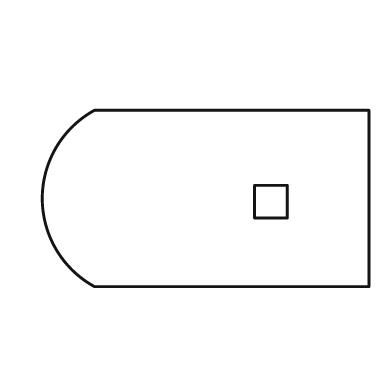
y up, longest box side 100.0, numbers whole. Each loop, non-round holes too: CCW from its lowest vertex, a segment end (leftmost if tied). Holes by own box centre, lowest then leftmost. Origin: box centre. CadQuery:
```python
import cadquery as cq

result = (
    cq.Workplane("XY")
    .moveTo(-34.0, -27.0)
    .lineTo(50.0, -27.0)
    .lineTo(50.0, 27.0)
    .lineTo(-34.0, 27.0)
    .threePointArc((-50.0, 0.0), (-34.0, -27.0))
    .close()
    .moveTo(15.0, -6.0)
    .lineTo(25.0, -6.0)
    .lineTo(25.0, 4.0)
    .lineTo(15.0, 4.0)
    .close()
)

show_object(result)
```